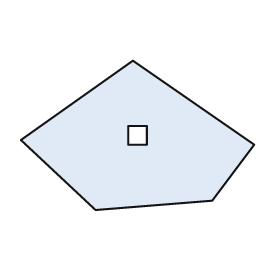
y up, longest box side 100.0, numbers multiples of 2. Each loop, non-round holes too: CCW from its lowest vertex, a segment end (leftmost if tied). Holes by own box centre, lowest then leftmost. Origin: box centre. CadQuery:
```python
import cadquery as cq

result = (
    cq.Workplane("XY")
    .moveTo(-18.0, -32.0)
    .lineTo(32.0, -28.0)
    .lineTo(50.0, -4.0)
    .lineTo(-2.0, 32.0)
    .lineTo(-50.0, -2.0)
    .close()
    .moveTo(-4.0, -4.0)
    .lineTo(4.0, -4.0)
    .lineTo(4.0, 4.0)
    .lineTo(-4.0, 4.0)
    .close()
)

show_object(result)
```